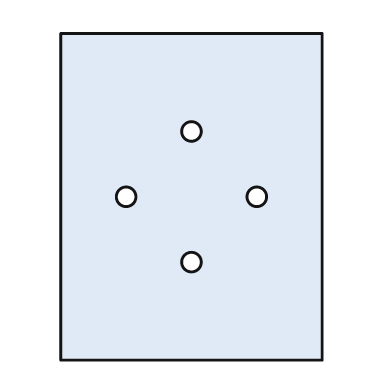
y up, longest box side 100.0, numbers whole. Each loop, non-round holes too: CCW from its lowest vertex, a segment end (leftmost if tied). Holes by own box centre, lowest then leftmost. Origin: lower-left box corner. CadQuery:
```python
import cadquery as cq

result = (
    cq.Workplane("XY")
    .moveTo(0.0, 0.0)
    .lineTo(80.0, 0.0)
    .lineTo(80.0, 100.0)
    .lineTo(0.0, 100.0)
    .close()
    .moveTo(40.0, 30.0)
    .circle(3.0)
    .moveTo(20.0, 50.0)
    .circle(3.0)
    .moveTo(60.0, 50.0)
    .circle(3.0)
    .moveTo(40.0, 70.0)
    .circle(3.0)
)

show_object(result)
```